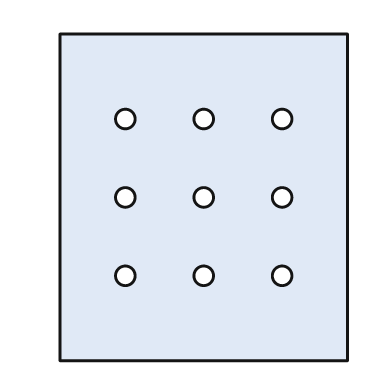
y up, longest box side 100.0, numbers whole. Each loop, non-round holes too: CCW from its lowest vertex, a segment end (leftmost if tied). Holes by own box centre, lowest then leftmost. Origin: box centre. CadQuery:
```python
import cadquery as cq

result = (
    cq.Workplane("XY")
    .moveTo(-44.0, -50.0)
    .lineTo(44.0, -50.0)
    .lineTo(44.0, 50.0)
    .lineTo(-44.0, 50.0)
    .close()
    .moveTo(-24.0, -24.0)
    .circle(3.0)
    .moveTo(0.0, -24.0)
    .circle(3.0)
    .moveTo(24.0, -24.0)
    .circle(3.0)
    .moveTo(-24.0, 0.0)
    .circle(3.0)
    .moveTo(0.0, 0.0)
    .circle(3.0)
    .moveTo(24.0, 0.0)
    .circle(3.0)
    .moveTo(-24.0, 24.0)
    .circle(3.0)
    .moveTo(0.0, 24.0)
    .circle(3.0)
    .moveTo(24.0, 24.0)
    .circle(3.0)
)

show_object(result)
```